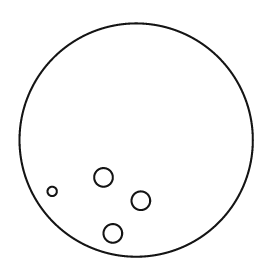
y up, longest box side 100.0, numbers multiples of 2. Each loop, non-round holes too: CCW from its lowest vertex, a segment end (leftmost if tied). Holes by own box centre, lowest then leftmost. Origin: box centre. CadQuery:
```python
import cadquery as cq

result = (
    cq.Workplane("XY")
    .moveTo(0.0, 0.0)
    .circle(50.0)
    .moveTo(-10.0, -40.0)
    .circle(4.0)
    .moveTo(2.0, -26.0)
    .circle(4.0)
    .moveTo(-36.0, -22.0)
    .circle(2.0)
    .moveTo(-14.0, -16.0)
    .circle(4.0)
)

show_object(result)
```